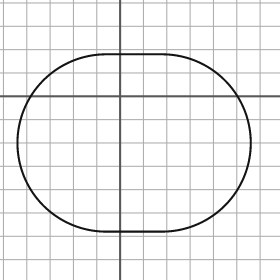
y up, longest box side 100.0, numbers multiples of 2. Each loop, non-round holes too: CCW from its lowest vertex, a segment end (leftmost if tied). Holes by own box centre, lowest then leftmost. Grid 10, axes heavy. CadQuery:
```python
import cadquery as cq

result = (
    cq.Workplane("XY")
    .moveTo(-6.0, -58.0)
    .lineTo(18.0, -58.0)
    .threePointArc((56.0, -20.0), (18.0, 18.0))
    .lineTo(-6.0, 18.0)
    .threePointArc((-44.0, -20.0), (-6.0, -58.0))
    .close()
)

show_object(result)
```